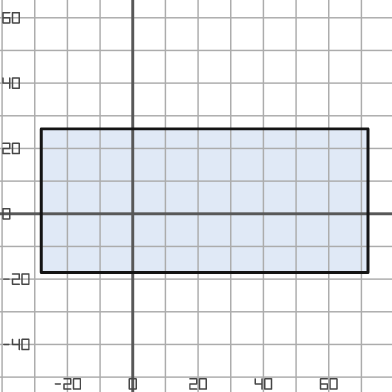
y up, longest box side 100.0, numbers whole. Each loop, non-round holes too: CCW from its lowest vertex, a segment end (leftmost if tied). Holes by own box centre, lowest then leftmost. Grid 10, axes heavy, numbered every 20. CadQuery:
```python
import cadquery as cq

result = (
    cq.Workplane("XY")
    .moveTo(-28.0, -18.0)
    .lineTo(72.0, -18.0)
    .lineTo(72.0, 26.0)
    .lineTo(-28.0, 26.0)
    .close()
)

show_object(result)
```